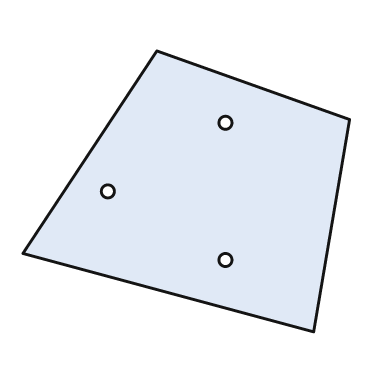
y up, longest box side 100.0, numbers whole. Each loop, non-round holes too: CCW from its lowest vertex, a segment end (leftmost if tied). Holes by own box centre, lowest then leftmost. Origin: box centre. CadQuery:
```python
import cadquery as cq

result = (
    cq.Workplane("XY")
    .moveTo(39.0, -43.0)
    .lineTo(50.0, 22.0)
    .lineTo(-9.0, 43.0)
    .lineTo(-50.0, -19.0)
    .close()
    .moveTo(12.0, -21.0)
    .circle(2.0)
    .moveTo(-24.0, 0.0)
    .circle(2.0)
    .moveTo(12.0, 21.0)
    .circle(2.0)
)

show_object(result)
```